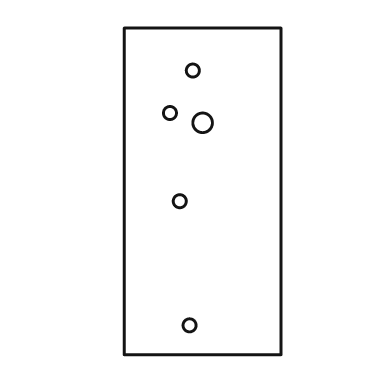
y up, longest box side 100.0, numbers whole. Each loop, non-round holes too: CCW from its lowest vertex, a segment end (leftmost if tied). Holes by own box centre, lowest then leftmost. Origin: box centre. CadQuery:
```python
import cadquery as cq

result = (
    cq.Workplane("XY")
    .moveTo(-24.0, -50.0)
    .lineTo(24.0, -50.0)
    .lineTo(24.0, 50.0)
    .lineTo(-24.0, 50.0)
    .close()
    .moveTo(-4.0, -41.0)
    .circle(2.0)
    .moveTo(-7.0, -3.0)
    .circle(2.0)
    .moveTo(0.0, 21.0)
    .circle(3.0)
    .moveTo(-10.0, 24.0)
    .circle(2.0)
    .moveTo(-3.0, 37.0)
    .circle(2.0)
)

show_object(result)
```